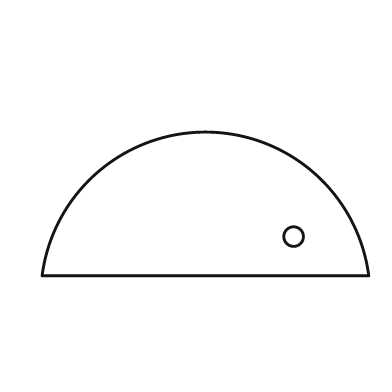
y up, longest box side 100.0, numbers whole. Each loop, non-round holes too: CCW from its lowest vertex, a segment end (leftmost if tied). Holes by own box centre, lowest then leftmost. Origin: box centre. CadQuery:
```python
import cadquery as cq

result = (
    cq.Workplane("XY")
    .moveTo(-50.0, -22.0)
    .lineTo(50.0, -22.0)
    .threePointArc((0.0, 22.0), (-50.0, -22.0))
    .close()
    .moveTo(27.0, -10.0)
    .circle(3.0)
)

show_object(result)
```